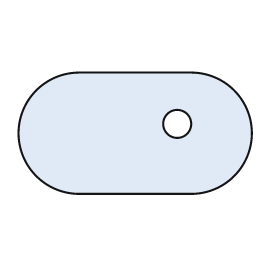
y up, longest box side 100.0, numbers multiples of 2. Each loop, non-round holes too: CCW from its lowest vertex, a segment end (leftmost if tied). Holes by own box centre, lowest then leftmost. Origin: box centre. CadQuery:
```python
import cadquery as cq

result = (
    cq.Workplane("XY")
    .moveTo(-24.0, -26.0)
    .lineTo(24.0, -26.0)
    .threePointArc((50.0, 0.0), (24.0, 26.0))
    .lineTo(-24.0, 26.0)
    .threePointArc((-50.0, 0.0), (-24.0, -26.0))
    .close()
    .moveTo(18.0, 4.0)
    .circle(6.0)
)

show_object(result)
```